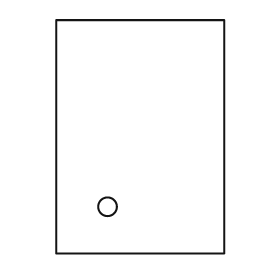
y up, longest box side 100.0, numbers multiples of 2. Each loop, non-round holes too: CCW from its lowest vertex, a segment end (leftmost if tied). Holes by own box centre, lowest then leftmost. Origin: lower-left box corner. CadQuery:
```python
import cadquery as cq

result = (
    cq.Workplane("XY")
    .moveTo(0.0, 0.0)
    .lineTo(72.0, 0.0)
    .lineTo(72.0, 100.0)
    .lineTo(0.0, 100.0)
    .close()
    .moveTo(22.0, 20.0)
    .circle(4.0)
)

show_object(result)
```